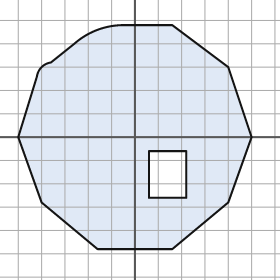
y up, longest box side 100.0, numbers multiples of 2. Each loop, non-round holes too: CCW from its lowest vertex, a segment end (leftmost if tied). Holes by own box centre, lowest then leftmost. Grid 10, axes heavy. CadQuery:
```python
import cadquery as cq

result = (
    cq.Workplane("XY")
    .moveTo(-16.0, -48.0)
    .lineTo(16.0, -48.0)
    .lineTo(40.0, -28.0)
    .lineTo(50.0, 0.0)
    .lineTo(40.0, 30.0)
    .lineTo(16.0, 48.0)
    .lineTo(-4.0, 48.0)
    .threePointArc((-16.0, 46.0), (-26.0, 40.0))
    .lineTo(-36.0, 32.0)
    .threePointArc((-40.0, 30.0), (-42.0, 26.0))
    .lineTo(-50.0, 0.0)
    .lineTo(-40.0, -28.0)
    .close()
    .moveTo(6.0, -26.0)
    .lineTo(22.0, -26.0)
    .lineTo(22.0, -6.0)
    .lineTo(6.0, -6.0)
    .close()
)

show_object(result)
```